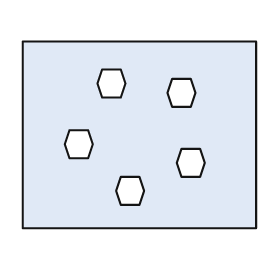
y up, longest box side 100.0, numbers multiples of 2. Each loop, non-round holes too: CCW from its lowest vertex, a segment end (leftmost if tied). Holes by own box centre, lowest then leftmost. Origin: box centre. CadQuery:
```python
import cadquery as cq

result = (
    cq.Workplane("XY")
    .moveTo(-50.0, -40.0)
    .lineTo(50.0, -40.0)
    .lineTo(50.0, 40.0)
    .lineTo(-50.0, 40.0)
    .close()
    .moveTo(-8.0, -30.0)
    .lineTo(0.0, -30.0)
    .lineTo(2.0, -24.0)
    .lineTo(0.0, -18.0)
    .lineTo(-8.0, -18.0)
    .lineTo(-10.0, -24.0)
    .close()
    .moveTo(18.0, -18.0)
    .lineTo(26.0, -18.0)
    .lineTo(28.0, -12.0)
    .lineTo(26.0, -6.0)
    .lineTo(18.0, -6.0)
    .lineTo(16.0, -12.0)
    .close()
    .moveTo(-30.0, -10.0)
    .lineTo(-22.0, -10.0)
    .lineTo(-20.0, -4.0)
    .lineTo(-22.0, 2.0)
    .lineTo(-30.0, 2.0)
    .lineTo(-32.0, -4.0)
    .close()
    .moveTo(14.0, 12.0)
    .lineTo(22.0, 12.0)
    .lineTo(24.0, 18.0)
    .lineTo(22.0, 24.0)
    .lineTo(14.0, 24.0)
    .lineTo(12.0, 18.0)
    .close()
    .moveTo(-16.0, 16.0)
    .lineTo(-8.0, 16.0)
    .lineTo(-6.0, 22.0)
    .lineTo(-8.0, 28.0)
    .lineTo(-16.0, 28.0)
    .lineTo(-18.0, 22.0)
    .close()
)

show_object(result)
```